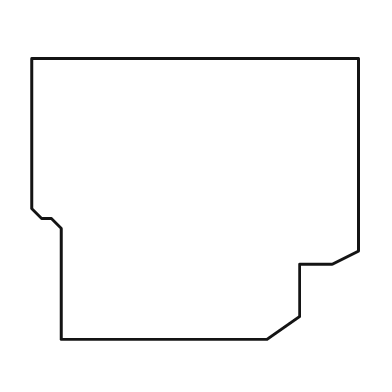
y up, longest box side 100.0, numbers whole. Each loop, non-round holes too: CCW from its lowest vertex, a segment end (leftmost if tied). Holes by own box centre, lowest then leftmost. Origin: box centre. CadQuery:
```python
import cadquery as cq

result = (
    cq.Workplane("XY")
    .moveTo(-41.0, -43.0)
    .lineTo(22.0, -43.0)
    .lineTo(32.0, -36.0)
    .lineTo(32.0, -20.0)
    .lineTo(42.0, -20.0)
    .lineTo(50.0, -16.0)
    .lineTo(50.0, 43.0)
    .lineTo(-50.0, 43.0)
    .lineTo(-50.0, -3.0)
    .lineTo(-47.0, -6.0)
    .lineTo(-44.0, -6.0)
    .lineTo(-41.0, -9.0)
    .close()
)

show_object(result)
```